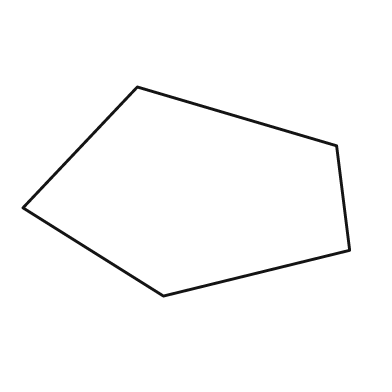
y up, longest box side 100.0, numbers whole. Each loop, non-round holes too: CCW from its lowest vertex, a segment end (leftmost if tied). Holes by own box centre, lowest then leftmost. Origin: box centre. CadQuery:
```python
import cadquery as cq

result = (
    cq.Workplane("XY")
    .moveTo(-7.0, -32.0)
    .lineTo(50.0, -18.0)
    .lineTo(46.0, 14.0)
    .lineTo(-15.0, 32.0)
    .lineTo(-50.0, -5.0)
    .close()
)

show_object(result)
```